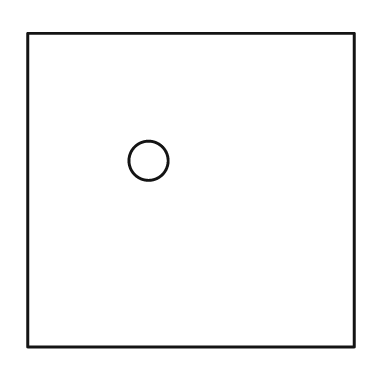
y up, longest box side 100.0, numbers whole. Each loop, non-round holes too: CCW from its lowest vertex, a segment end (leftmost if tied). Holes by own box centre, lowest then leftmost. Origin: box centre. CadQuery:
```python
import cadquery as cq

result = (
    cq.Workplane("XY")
    .moveTo(-50.0, -48.0)
    .lineTo(50.0, -48.0)
    .lineTo(50.0, 48.0)
    .lineTo(-50.0, 48.0)
    .close()
    .moveTo(-13.0, 9.0)
    .circle(6.0)
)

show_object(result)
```